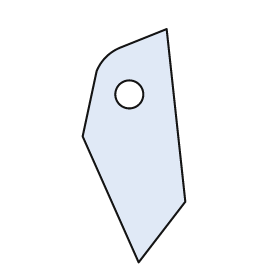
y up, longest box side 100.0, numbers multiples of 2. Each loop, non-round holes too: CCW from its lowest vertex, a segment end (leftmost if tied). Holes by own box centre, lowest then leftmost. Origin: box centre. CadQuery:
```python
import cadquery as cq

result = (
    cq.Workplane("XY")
    .moveTo(2.0, -50.0)
    .lineTo(22.0, -24.0)
    .lineTo(14.0, 50.0)
    .lineTo(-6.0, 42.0)
    .threePointArc((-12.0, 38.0), (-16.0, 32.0))
    .lineTo(-22.0, 4.0)
    .close()
    .moveTo(-2.0, 22.0)
    .circle(6.0)
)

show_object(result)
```